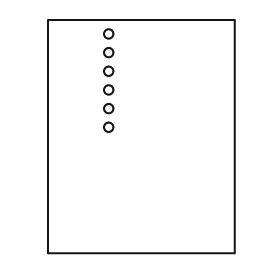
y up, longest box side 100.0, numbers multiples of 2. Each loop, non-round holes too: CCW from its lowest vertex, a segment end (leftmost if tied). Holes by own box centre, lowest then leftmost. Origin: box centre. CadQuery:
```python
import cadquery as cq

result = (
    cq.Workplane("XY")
    .moveTo(-40.0, -50.0)
    .lineTo(40.0, -50.0)
    .lineTo(40.0, 50.0)
    .lineTo(-40.0, 50.0)
    .close()
    .moveTo(-14.0, 4.0)
    .circle(2.0)
    .moveTo(-14.0, 12.0)
    .circle(2.0)
    .moveTo(-14.0, 20.0)
    .circle(2.0)
    .moveTo(-14.0, 28.0)
    .circle(2.0)
    .moveTo(-14.0, 36.0)
    .circle(2.0)
    .moveTo(-14.0, 44.0)
    .circle(2.0)
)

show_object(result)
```